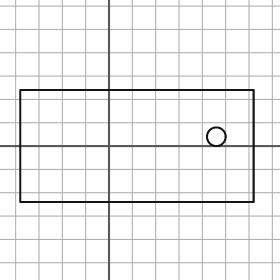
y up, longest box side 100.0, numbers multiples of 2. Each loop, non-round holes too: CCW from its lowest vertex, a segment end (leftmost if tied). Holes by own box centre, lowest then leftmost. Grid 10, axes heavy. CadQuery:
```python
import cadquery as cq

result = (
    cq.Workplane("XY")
    .moveTo(-38.0, -24.0)
    .lineTo(62.0, -24.0)
    .lineTo(62.0, 24.0)
    .lineTo(-38.0, 24.0)
    .close()
    .moveTo(46.0, 4.0)
    .circle(4.0)
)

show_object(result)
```